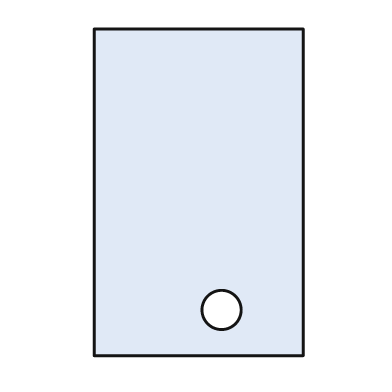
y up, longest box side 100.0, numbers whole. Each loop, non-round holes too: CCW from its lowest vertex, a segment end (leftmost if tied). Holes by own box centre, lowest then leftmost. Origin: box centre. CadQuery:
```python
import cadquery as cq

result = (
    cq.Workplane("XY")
    .moveTo(-32.0, -50.0)
    .lineTo(32.0, -50.0)
    .lineTo(32.0, 50.0)
    .lineTo(-32.0, 50.0)
    .close()
    .moveTo(7.0, -36.0)
    .circle(6.0)
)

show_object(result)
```